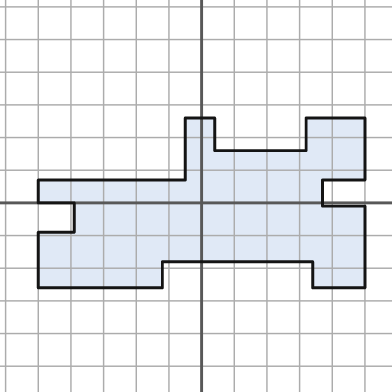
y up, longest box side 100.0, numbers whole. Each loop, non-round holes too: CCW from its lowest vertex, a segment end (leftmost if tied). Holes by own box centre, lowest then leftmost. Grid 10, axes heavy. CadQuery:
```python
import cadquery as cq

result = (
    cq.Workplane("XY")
    .moveTo(-50.0, -26.0)
    .lineTo(-12.0, -26.0)
    .lineTo(-12.0, -18.0)
    .lineTo(34.0, -18.0)
    .lineTo(34.0, -26.0)
    .lineTo(50.0, -26.0)
    .lineTo(50.0, -1.0)
    .lineTo(37.0, -1.0)
    .lineTo(37.0, 7.0)
    .lineTo(50.0, 7.0)
    .lineTo(50.0, 26.0)
    .lineTo(32.0, 26.0)
    .lineTo(32.0, 16.0)
    .lineTo(4.0, 16.0)
    .lineTo(4.0, 26.0)
    .lineTo(-5.0, 26.0)
    .lineTo(-5.0, 7.0)
    .lineTo(-50.0, 7.0)
    .lineTo(-50.0, 0.0)
    .lineTo(-39.0, 0.0)
    .lineTo(-39.0, -9.0)
    .lineTo(-50.0, -9.0)
    .close()
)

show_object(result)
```